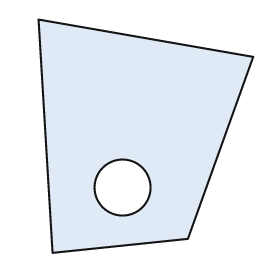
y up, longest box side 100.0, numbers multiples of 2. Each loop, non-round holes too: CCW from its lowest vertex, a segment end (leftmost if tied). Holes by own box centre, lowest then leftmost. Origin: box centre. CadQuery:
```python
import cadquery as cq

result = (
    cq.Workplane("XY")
    .moveTo(-40.0, -50.0)
    .lineTo(18.0, -44.0)
    .lineTo(46.0, 34.0)
    .lineTo(-46.0, 50.0)
    .close()
    .moveTo(-10.0, -22.0)
    .circle(12.0)
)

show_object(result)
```